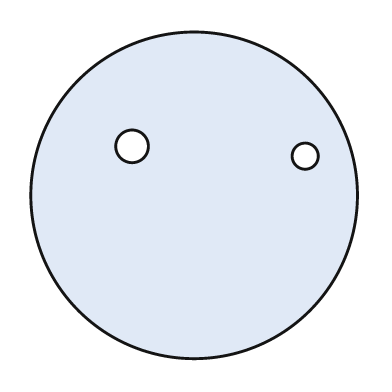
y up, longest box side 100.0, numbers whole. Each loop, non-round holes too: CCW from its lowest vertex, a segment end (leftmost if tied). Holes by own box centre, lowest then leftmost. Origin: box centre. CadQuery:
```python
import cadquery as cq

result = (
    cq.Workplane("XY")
    .moveTo(0.0, 0.0)
    .circle(50.0)
    .moveTo(34.0, 12.0)
    .circle(4.0)
    .moveTo(-19.0, 15.0)
    .circle(5.0)
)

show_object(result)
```